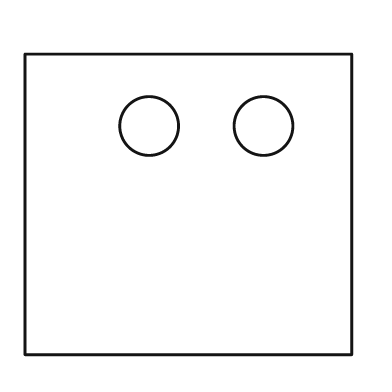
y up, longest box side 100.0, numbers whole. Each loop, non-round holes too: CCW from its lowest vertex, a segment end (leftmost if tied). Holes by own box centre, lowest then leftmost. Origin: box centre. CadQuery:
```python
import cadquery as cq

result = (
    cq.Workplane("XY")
    .moveTo(-50.0, -46.0)
    .lineTo(50.0, -46.0)
    .lineTo(50.0, 46.0)
    .lineTo(-50.0, 46.0)
    .close()
    .moveTo(-12.0, 24.0)
    .circle(9.0)
    .moveTo(23.0, 24.0)
    .circle(9.0)
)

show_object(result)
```